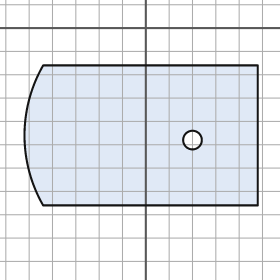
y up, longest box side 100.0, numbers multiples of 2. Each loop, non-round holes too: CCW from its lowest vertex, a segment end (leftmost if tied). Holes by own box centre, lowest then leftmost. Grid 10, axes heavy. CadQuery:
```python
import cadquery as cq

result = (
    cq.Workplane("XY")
    .moveTo(-44.0, -76.0)
    .lineTo(48.0, -76.0)
    .lineTo(48.0, -16.0)
    .lineTo(-44.0, -16.0)
    .threePointArc((-52.0, -46.0), (-44.0, -76.0))
    .close()
    .moveTo(20.0, -48.0)
    .circle(4.0)
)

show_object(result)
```